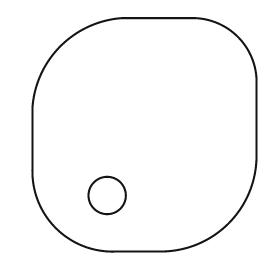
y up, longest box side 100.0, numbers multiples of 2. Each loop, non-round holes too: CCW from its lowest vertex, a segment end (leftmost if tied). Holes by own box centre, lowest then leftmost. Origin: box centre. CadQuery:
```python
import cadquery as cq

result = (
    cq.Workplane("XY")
    .moveTo(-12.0, -50.0)
    .lineTo(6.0, -50.0)
    .threePointArc((36.0, -38.0), (48.0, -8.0))
    .lineTo(48.0, 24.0)
    .threePointArc((40.0, 42.0), (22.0, 50.0))
    .lineTo(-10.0, 50.0)
    .threePointArc((-36.0, 38.0), (-48.0, 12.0))
    .lineTo(-48.0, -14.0)
    .threePointArc((-38.0, -40.0), (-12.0, -50.0))
    .close()
    .moveTo(-16.0, -26.0)
    .circle(8.0)
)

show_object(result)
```